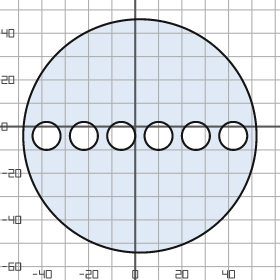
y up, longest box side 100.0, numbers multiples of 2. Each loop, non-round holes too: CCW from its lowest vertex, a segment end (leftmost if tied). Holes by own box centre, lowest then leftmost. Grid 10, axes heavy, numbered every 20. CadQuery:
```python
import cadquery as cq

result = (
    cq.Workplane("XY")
    .moveTo(2.0, -4.0)
    .circle(50.0)
    .moveTo(-38.0, -4.0)
    .circle(6.0)
    .moveTo(-22.0, -4.0)
    .circle(6.0)
    .moveTo(-6.0, -4.0)
    .circle(6.0)
    .moveTo(10.0, -4.0)
    .circle(6.0)
    .moveTo(26.0, -4.0)
    .circle(6.0)
    .moveTo(42.0, -4.0)
    .circle(6.0)
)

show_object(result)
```